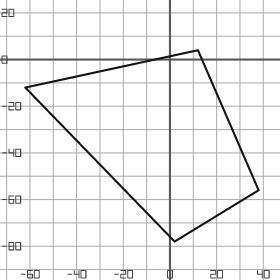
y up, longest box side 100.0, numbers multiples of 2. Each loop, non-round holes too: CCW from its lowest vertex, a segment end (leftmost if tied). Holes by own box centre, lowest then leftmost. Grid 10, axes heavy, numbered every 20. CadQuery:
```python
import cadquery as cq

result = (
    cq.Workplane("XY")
    .moveTo(2.0, -78.0)
    .lineTo(38.0, -56.0)
    .lineTo(12.0, 4.0)
    .lineTo(-62.0, -12.0)
    .close()
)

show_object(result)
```